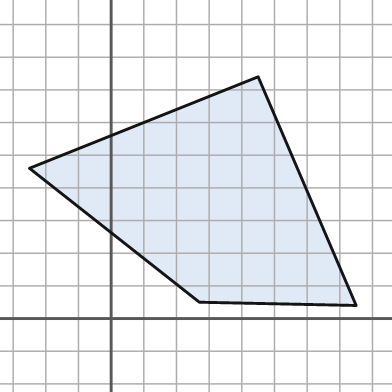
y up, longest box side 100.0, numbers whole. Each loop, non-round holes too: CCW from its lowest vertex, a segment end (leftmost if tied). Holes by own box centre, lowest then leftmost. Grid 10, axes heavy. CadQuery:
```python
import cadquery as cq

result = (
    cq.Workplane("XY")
    .moveTo(75.0, 4.0)
    .lineTo(45.0, 74.0)
    .lineTo(-25.0, 46.0)
    .lineTo(27.0, 5.0)
    .close()
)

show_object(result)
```